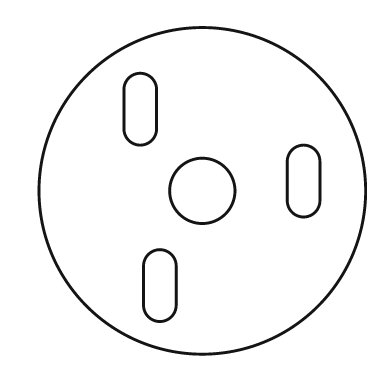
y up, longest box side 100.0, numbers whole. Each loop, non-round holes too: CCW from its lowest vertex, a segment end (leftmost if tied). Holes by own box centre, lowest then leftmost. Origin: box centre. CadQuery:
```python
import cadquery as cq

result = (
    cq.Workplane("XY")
    .moveTo(0.0, 0.0)
    .circle(50.0)
    .moveTo(-18.0, -35.0)
    .threePointArc((-13.0, -40.0), (-8.0, -35.0))
    .lineTo(-8.0, -23.0)
    .threePointArc((-13.0, -18.0), (-18.0, -23.0))
    .close()
    .moveTo(0.0, 0.0)
    .circle(10.0)
    .moveTo(26.0, -3.0)
    .threePointArc((31.0, -8.0), (36.0, -3.0))
    .lineTo(36.0, 9.0)
    .threePointArc((31.0, 14.0), (26.0, 9.0))
    .close()
    .moveTo(-24.0, 19.0)
    .threePointArc((-19.0, 14.0), (-14.0, 19.0))
    .lineTo(-14.0, 31.0)
    .threePointArc((-19.0, 36.0), (-24.0, 31.0))
    .close()
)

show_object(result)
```